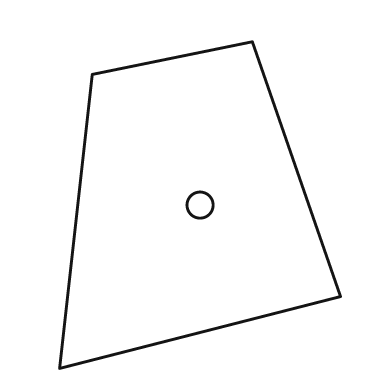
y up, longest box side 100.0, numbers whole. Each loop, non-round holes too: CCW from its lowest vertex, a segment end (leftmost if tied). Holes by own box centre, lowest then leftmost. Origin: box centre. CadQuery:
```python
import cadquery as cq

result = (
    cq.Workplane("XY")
    .moveTo(-43.0, -50.0)
    .lineTo(43.0, -28.0)
    .lineTo(16.0, 50.0)
    .lineTo(-33.0, 40.0)
    .close()
    .moveTo(0.0, 0.0)
    .circle(4.0)
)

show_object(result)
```